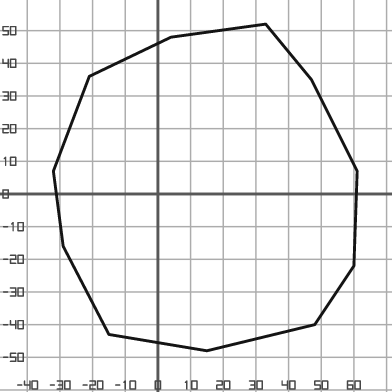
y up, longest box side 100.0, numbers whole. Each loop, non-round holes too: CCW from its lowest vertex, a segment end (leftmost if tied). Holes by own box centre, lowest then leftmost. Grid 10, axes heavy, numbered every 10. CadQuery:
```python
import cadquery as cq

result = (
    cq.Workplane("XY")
    .moveTo(15.0, -48.0)
    .lineTo(48.0, -40.0)
    .lineTo(60.0, -22.0)
    .lineTo(61.0, 7.0)
    .lineTo(47.0, 35.0)
    .lineTo(33.0, 52.0)
    .lineTo(4.0, 48.0)
    .lineTo(-21.0, 36.0)
    .lineTo(-32.0, 7.0)
    .lineTo(-29.0, -16.0)
    .lineTo(-15.0, -43.0)
    .close()
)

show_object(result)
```